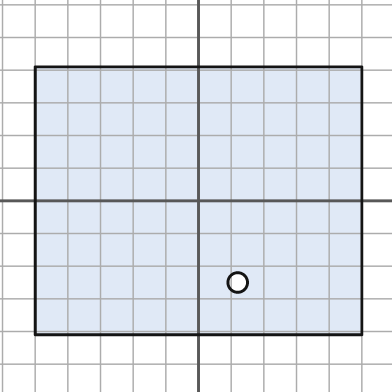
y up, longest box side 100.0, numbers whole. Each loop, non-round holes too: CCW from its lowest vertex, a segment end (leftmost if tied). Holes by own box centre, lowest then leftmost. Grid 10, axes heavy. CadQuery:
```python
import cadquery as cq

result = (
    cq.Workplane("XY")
    .moveTo(-50.0, -41.0)
    .lineTo(50.0, -41.0)
    .lineTo(50.0, 41.0)
    .lineTo(-50.0, 41.0)
    .close()
    .moveTo(12.0, -25.0)
    .circle(3.0)
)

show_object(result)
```